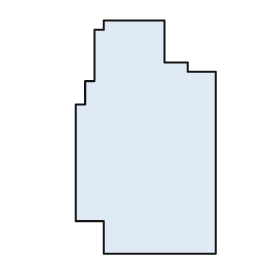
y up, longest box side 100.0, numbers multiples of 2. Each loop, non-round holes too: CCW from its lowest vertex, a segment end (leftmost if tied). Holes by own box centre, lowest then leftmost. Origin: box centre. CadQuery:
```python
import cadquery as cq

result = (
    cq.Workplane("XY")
    .moveTo(-18.0, -50.0)
    .lineTo(30.0, -50.0)
    .lineTo(30.0, 28.0)
    .lineTo(18.0, 28.0)
    .lineTo(18.0, 32.0)
    .lineTo(8.0, 32.0)
    .lineTo(8.0, 50.0)
    .lineTo(-18.0, 50.0)
    .lineTo(-18.0, 46.0)
    .lineTo(-22.0, 46.0)
    .lineTo(-22.0, 24.0)
    .lineTo(-26.0, 24.0)
    .lineTo(-26.0, 14.0)
    .lineTo(-30.0, 14.0)
    .lineTo(-30.0, -36.0)
    .lineTo(-18.0, -36.0)
    .close()
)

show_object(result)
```